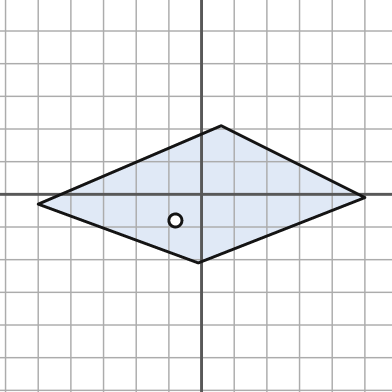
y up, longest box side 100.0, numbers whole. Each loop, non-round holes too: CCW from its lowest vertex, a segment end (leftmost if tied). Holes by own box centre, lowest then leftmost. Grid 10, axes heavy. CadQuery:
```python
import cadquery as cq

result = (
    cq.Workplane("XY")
    .moveTo(-1.0, -21.0)
    .lineTo(50.0, -1.0)
    .lineTo(6.0, 21.0)
    .lineTo(-50.0, -3.0)
    .close()
    .moveTo(-8.0, -8.0)
    .circle(2.0)
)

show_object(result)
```